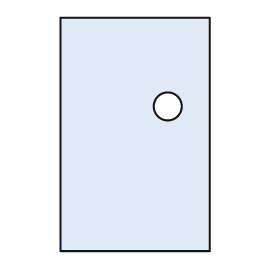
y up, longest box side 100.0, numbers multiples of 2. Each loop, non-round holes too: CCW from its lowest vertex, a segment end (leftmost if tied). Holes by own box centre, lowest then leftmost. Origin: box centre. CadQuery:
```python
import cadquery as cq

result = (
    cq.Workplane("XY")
    .moveTo(-32.0, -50.0)
    .lineTo(32.0, -50.0)
    .lineTo(32.0, 50.0)
    .lineTo(-32.0, 50.0)
    .close()
    .moveTo(14.0, 12.0)
    .circle(6.0)
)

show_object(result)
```